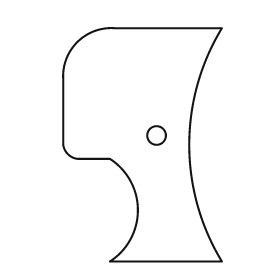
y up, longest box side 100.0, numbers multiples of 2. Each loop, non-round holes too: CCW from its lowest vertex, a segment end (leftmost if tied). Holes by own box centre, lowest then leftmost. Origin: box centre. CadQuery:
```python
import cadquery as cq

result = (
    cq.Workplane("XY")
    .moveTo(-14.0, -50.0)
    .lineTo(34.0, -50.0)
    .threePointArc((20.0, 0.0), (34.0, 50.0))
    .lineTo(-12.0, 50.0)
    .threePointArc((-28.0, 44.0), (-34.0, 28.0))
    .lineTo(-34.0, 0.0)
    .threePointArc((-32.0, -4.0), (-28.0, -6.0))
    .lineTo(-14.0, -6.0)
    .threePointArc((-2.0, -28.0), (-14.0, -50.0))
    .close()
    .moveTo(6.0, 4.0)
    .circle(4.0)
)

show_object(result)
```